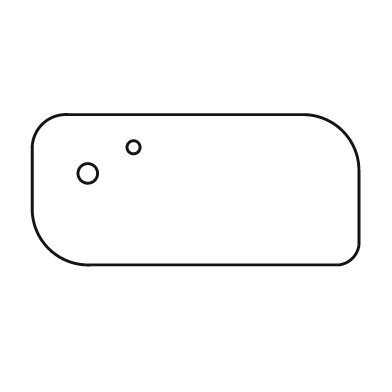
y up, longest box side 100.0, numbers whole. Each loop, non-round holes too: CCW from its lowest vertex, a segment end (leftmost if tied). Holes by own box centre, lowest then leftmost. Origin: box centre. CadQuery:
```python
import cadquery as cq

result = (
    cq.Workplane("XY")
    .moveTo(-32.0, -23.0)
    .lineTo(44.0, -23.0)
    .threePointArc((48.0, -21.0), (50.0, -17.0))
    .lineTo(50.0, 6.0)
    .threePointArc((45.0, 18.0), (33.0, 23.0))
    .lineTo(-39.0, 23.0)
    .threePointArc((-47.0, 20.0), (-50.0, 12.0))
    .lineTo(-50.0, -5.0)
    .threePointArc((-45.0, -18.0), (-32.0, -23.0))
    .close()
    .moveTo(-33.0, 5.0)
    .circle(3.0)
    .moveTo(-19.0, 13.0)
    .circle(2.0)
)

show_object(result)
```